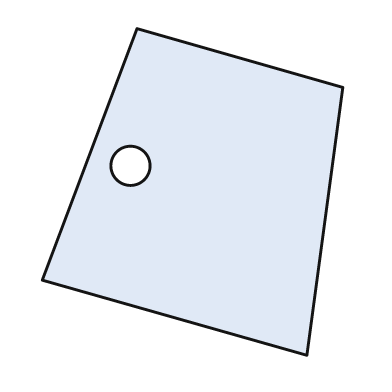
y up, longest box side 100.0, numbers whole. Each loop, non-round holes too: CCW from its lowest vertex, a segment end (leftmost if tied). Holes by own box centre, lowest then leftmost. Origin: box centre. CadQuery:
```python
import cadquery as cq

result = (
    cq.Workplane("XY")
    .moveTo(35.0, -50.0)
    .lineTo(46.0, 32.0)
    .lineTo(-17.0, 50.0)
    .lineTo(-46.0, -27.0)
    .close()
    .moveTo(-19.0, 8.0)
    .circle(6.0)
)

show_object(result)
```